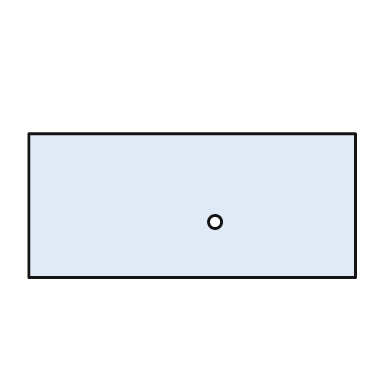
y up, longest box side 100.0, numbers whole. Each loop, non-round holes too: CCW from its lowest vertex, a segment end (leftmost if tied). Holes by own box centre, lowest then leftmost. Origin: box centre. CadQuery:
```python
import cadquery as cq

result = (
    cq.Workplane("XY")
    .moveTo(-50.0, -22.0)
    .lineTo(50.0, -22.0)
    .lineTo(50.0, 22.0)
    .lineTo(-50.0, 22.0)
    .close()
    .moveTo(7.0, -5.0)
    .circle(2.0)
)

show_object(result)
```